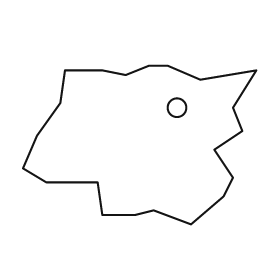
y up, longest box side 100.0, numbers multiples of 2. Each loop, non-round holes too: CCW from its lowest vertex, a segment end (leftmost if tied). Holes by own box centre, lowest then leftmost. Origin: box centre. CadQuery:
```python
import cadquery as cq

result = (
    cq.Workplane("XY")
    .moveTo(22.0, -34.0)
    .lineTo(36.0, -22.0)
    .lineTo(40.0, -14.0)
    .lineTo(32.0, -2.0)
    .lineTo(44.0, 6.0)
    .lineTo(40.0, 16.0)
    .lineTo(50.0, 32.0)
    .lineTo(26.0, 28.0)
    .lineTo(12.0, 34.0)
    .lineTo(4.0, 34.0)
    .lineTo(-6.0, 30.0)
    .lineTo(-16.0, 32.0)
    .lineTo(-32.0, 32.0)
    .lineTo(-34.0, 18.0)
    .lineTo(-44.0, 4.0)
    .lineTo(-50.0, -10.0)
    .lineTo(-40.0, -16.0)
    .lineTo(-18.0, -16.0)
    .lineTo(-16.0, -30.0)
    .lineTo(-2.0, -30.0)
    .lineTo(6.0, -28.0)
    .close()
    .moveTo(16.0, 16.0)
    .circle(4.0)
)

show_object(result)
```